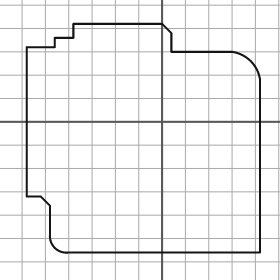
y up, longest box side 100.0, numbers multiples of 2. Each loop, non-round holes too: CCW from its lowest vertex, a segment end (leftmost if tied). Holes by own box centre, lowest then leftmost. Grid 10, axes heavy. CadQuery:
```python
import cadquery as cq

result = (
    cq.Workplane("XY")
    .moveTo(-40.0, -56.0)
    .lineTo(42.0, -56.0)
    .lineTo(42.0, 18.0)
    .threePointArc((38.0, 26.0), (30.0, 30.0))
    .lineTo(4.0, 30.0)
    .lineTo(4.0, 38.0)
    .lineTo(0.0, 42.0)
    .lineTo(-38.0, 42.0)
    .lineTo(-38.0, 36.0)
    .lineTo(-46.0, 36.0)
    .lineTo(-46.0, 32.0)
    .lineTo(-58.0, 32.0)
    .lineTo(-58.0, -32.0)
    .lineTo(-52.0, -32.0)
    .lineTo(-48.0, -36.0)
    .lineTo(-48.0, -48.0)
    .threePointArc((-46.0, -54.0), (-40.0, -56.0))
    .close()
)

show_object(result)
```